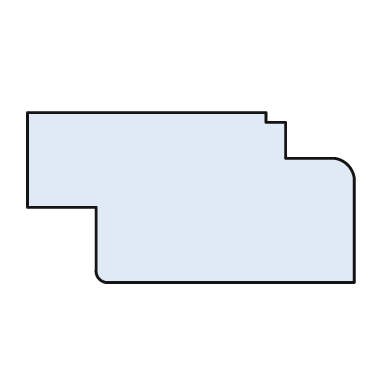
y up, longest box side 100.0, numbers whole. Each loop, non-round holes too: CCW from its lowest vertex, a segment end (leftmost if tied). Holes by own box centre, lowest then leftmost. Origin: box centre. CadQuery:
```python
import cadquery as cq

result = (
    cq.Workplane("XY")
    .moveTo(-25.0, -26.0)
    .lineTo(50.0, -26.0)
    .lineTo(50.0, 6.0)
    .threePointArc((48.0, 10.0), (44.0, 12.0))
    .lineTo(29.0, 12.0)
    .lineTo(29.0, 23.0)
    .lineTo(23.0, 23.0)
    .lineTo(23.0, 26.0)
    .lineTo(-50.0, 26.0)
    .lineTo(-50.0, -3.0)
    .lineTo(-29.0, -3.0)
    .lineTo(-29.0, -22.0)
    .threePointArc((-28.0, -25.0), (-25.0, -26.0))
    .close()
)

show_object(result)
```